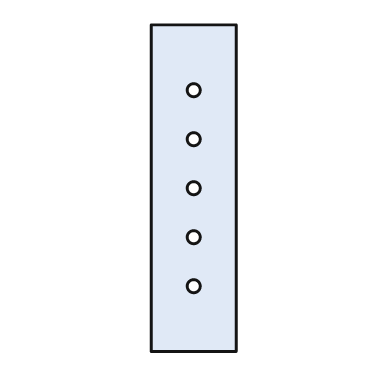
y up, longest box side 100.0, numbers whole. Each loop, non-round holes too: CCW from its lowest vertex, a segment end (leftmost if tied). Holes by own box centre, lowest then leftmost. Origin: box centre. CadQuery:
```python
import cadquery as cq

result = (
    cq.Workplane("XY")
    .moveTo(-13.0, -50.0)
    .lineTo(13.0, -50.0)
    .lineTo(13.0, 50.0)
    .lineTo(-13.0, 50.0)
    .close()
    .moveTo(0.0, -30.0)
    .circle(2.0)
    .moveTo(0.0, -15.0)
    .circle(2.0)
    .moveTo(0.0, 0.0)
    .circle(2.0)
    .moveTo(0.0, 15.0)
    .circle(2.0)
    .moveTo(0.0, 30.0)
    .circle(2.0)
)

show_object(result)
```